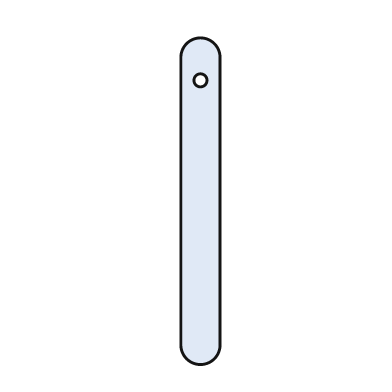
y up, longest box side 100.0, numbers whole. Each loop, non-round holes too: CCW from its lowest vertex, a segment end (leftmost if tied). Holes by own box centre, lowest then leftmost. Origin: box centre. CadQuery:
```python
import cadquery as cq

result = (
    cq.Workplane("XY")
    .moveTo(-6.0, -44.0)
    .threePointArc((0.0, -50.0), (6.0, -44.0))
    .lineTo(6.0, 44.0)
    .threePointArc((0.0, 50.0), (-6.0, 44.0))
    .close()
    .moveTo(0.0, 37.0)
    .circle(2.0)
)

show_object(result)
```